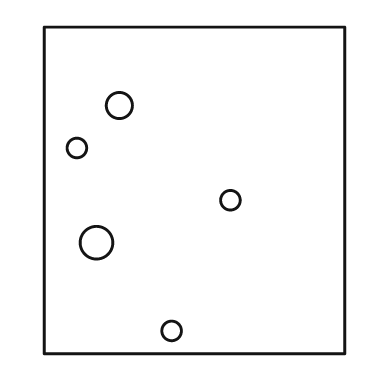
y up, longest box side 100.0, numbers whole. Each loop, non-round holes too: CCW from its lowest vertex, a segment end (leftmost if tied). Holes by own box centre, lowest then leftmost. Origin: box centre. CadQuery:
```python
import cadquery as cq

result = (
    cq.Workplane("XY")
    .moveTo(-46.0, -50.0)
    .lineTo(46.0, -50.0)
    .lineTo(46.0, 50.0)
    .lineTo(-46.0, 50.0)
    .close()
    .moveTo(-7.0, -43.0)
    .circle(3.0)
    .moveTo(-30.0, -16.0)
    .circle(5.0)
    .moveTo(11.0, -3.0)
    .circle(3.0)
    .moveTo(-36.0, 13.0)
    .circle(3.0)
    .moveTo(-23.0, 26.0)
    .circle(4.0)
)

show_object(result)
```